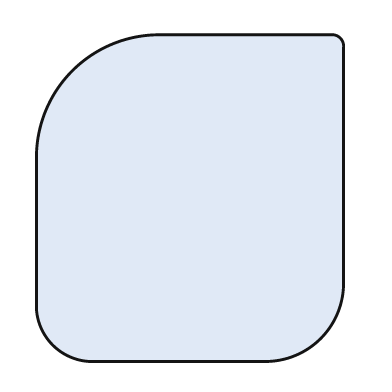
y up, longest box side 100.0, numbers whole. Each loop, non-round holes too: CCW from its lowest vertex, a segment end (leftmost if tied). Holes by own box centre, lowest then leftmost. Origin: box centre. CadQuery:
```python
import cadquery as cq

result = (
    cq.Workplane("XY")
    .moveTo(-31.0, -50.0)
    .lineTo(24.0, -50.0)
    .threePointArc((40.0, -43.0), (47.0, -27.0))
    .lineTo(47.0, 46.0)
    .threePointArc((46.0, 49.0), (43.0, 50.0))
    .lineTo(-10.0, 50.0)
    .threePointArc((-36.0, 39.0), (-47.0, 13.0))
    .lineTo(-47.0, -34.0)
    .threePointArc((-42.0, -45.0), (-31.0, -50.0))
    .close()
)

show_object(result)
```